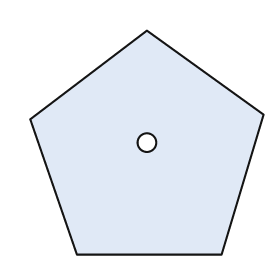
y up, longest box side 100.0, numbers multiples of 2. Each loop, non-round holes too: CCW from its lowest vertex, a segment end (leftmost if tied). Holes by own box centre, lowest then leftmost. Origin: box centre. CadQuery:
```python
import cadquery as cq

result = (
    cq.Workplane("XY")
    .moveTo(-30.0, -48.0)
    .lineTo(32.0, -48.0)
    .lineTo(50.0, 12.0)
    .lineTo(0.0, 48.0)
    .lineTo(-50.0, 10.0)
    .close()
    .moveTo(0.0, 0.0)
    .circle(4.0)
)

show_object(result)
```